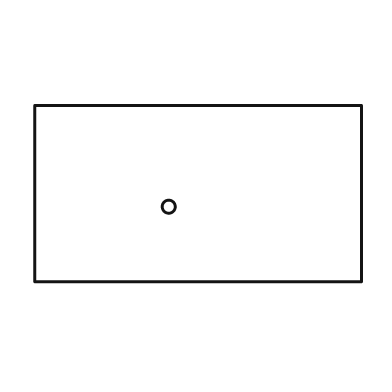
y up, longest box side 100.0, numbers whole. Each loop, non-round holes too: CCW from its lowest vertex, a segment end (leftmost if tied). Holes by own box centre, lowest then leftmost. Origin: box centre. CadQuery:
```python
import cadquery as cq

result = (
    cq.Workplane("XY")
    .moveTo(-50.0, -27.0)
    .lineTo(50.0, -27.0)
    .lineTo(50.0, 27.0)
    .lineTo(-50.0, 27.0)
    .close()
    .moveTo(-9.0, -4.0)
    .circle(2.0)
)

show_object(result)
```